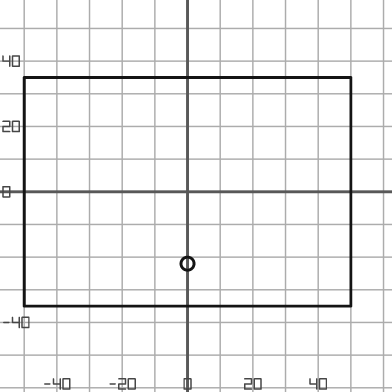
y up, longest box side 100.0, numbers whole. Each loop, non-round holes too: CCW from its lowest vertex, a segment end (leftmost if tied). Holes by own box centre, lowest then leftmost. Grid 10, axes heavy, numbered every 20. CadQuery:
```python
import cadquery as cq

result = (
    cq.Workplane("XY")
    .moveTo(-50.0, -35.0)
    .lineTo(50.0, -35.0)
    .lineTo(50.0, 35.0)
    .lineTo(-50.0, 35.0)
    .close()
    .moveTo(0.0, -22.0)
    .circle(2.0)
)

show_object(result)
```